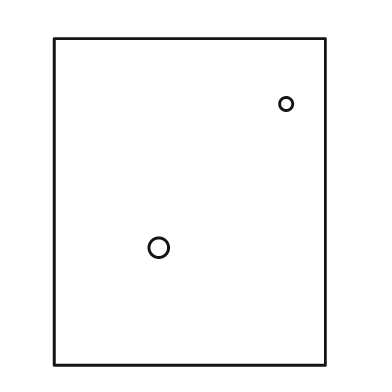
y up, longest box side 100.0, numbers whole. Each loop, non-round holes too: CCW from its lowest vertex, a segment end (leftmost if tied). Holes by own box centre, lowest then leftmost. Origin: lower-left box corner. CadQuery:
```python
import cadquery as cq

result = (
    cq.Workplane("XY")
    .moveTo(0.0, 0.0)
    .lineTo(83.0, 0.0)
    .lineTo(83.0, 100.0)
    .lineTo(0.0, 100.0)
    .close()
    .moveTo(32.0, 36.0)
    .circle(3.0)
    .moveTo(71.0, 80.0)
    .circle(2.0)
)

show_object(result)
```